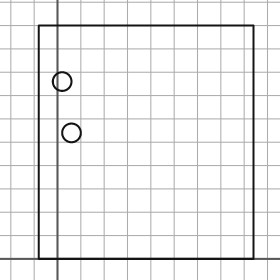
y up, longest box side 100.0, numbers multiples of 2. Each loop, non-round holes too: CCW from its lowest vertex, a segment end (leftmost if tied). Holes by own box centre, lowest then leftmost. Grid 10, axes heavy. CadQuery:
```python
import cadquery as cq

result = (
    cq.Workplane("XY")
    .moveTo(-8.0, 0.0)
    .lineTo(84.0, 0.0)
    .lineTo(84.0, 100.0)
    .lineTo(-8.0, 100.0)
    .close()
    .moveTo(6.0, 54.0)
    .circle(4.0)
    .moveTo(2.0, 76.0)
    .circle(4.0)
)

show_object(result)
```